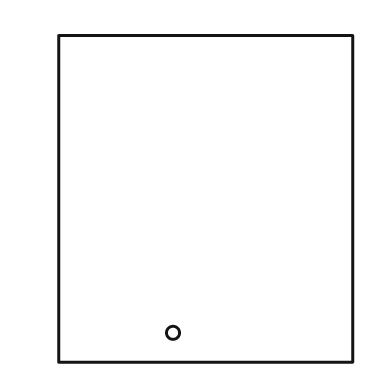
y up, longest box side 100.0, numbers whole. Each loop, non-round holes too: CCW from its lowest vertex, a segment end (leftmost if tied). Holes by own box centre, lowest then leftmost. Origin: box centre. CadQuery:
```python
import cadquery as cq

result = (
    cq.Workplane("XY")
    .moveTo(-45.0, -50.0)
    .lineTo(45.0, -50.0)
    .lineTo(45.0, 50.0)
    .lineTo(-45.0, 50.0)
    .close()
    .moveTo(-10.0, -41.0)
    .circle(2.0)
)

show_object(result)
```